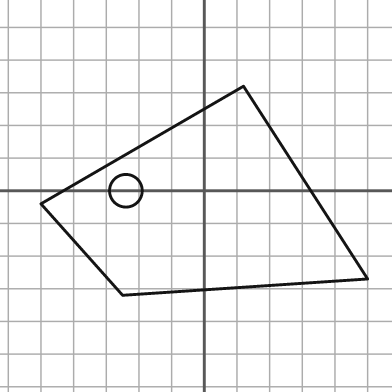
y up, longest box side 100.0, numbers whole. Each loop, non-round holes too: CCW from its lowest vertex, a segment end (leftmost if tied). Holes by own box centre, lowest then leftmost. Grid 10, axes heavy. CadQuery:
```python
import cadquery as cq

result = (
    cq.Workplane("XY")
    .moveTo(-25.0, -32.0)
    .lineTo(50.0, -27.0)
    .lineTo(12.0, 32.0)
    .lineTo(-50.0, -4.0)
    .close()
    .moveTo(-24.0, 0.0)
    .circle(5.0)
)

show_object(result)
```